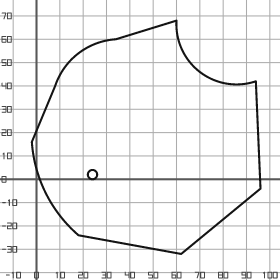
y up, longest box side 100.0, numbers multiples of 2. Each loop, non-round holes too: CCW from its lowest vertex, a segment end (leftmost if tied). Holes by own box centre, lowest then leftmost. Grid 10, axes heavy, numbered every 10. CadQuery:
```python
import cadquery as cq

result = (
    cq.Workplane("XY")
    .moveTo(62.0, -32.0)
    .lineTo(96.0, -4.0)
    .lineTo(94.0, 42.0)
    .threePointArc((70.0, 46.0), (60.0, 68.0))
    .lineTo(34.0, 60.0)
    .threePointArc((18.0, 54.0), (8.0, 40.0))
    .lineTo(-2.0, 16.0)
    .threePointArc((4.0, -6.0), (18.0, -24.0))
    .close()
    .moveTo(24.0, 2.0)
    .circle(2.0)
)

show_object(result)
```